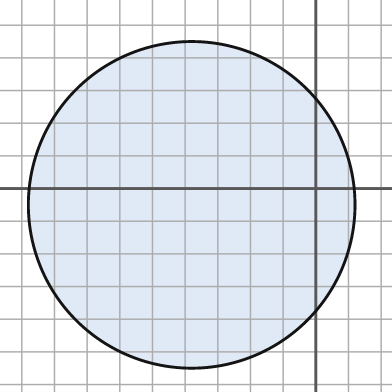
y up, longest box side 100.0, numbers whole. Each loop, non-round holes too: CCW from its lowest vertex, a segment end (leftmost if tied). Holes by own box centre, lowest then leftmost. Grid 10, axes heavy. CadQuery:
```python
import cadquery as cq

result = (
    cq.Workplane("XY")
    .moveTo(-38.0, -5.0)
    .circle(50.0)
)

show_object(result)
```